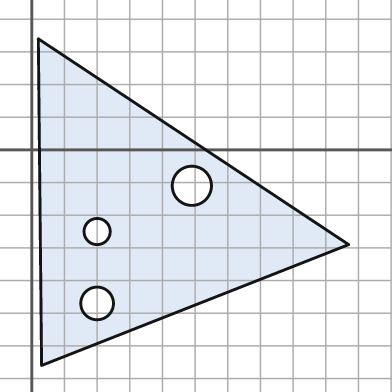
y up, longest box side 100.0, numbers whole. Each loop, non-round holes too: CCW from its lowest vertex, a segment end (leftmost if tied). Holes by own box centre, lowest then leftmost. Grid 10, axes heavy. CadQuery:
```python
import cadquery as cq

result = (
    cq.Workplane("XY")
    .moveTo(3.0, -66.0)
    .lineTo(97.0, -29.0)
    .lineTo(2.0, 34.0)
    .close()
    .moveTo(20.0, -47.0)
    .circle(5.0)
    .moveTo(20.0, -25.0)
    .circle(4.0)
    .moveTo(49.0, -11.0)
    .circle(6.0)
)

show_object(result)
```